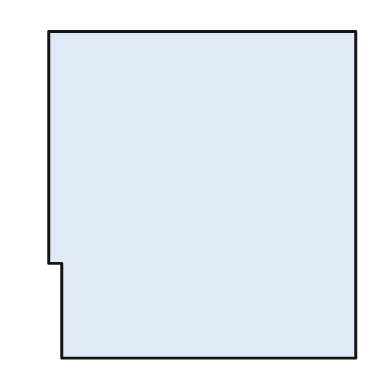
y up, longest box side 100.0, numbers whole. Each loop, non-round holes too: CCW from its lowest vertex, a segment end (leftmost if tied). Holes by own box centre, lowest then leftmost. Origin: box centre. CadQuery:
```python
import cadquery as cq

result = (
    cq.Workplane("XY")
    .moveTo(-43.0, -50.0)
    .lineTo(47.0, -50.0)
    .lineTo(47.0, 50.0)
    .lineTo(-47.0, 50.0)
    .lineTo(-47.0, -21.0)
    .lineTo(-43.0, -21.0)
    .close()
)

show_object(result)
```